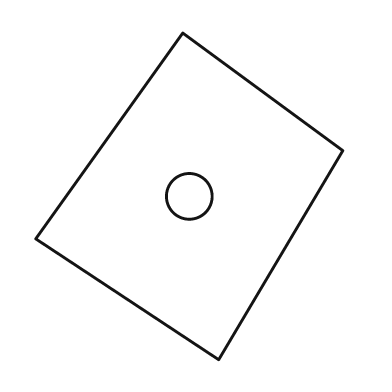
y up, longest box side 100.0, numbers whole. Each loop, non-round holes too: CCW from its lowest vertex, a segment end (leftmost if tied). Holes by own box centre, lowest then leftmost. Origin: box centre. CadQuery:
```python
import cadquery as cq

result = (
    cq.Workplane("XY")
    .moveTo(9.0, -50.0)
    .lineTo(47.0, 14.0)
    .lineTo(-2.0, 50.0)
    .lineTo(-47.0, -13.0)
    .close()
    .moveTo(0.0, 0.0)
    .circle(7.0)
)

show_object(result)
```